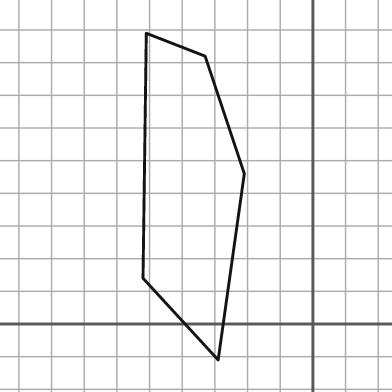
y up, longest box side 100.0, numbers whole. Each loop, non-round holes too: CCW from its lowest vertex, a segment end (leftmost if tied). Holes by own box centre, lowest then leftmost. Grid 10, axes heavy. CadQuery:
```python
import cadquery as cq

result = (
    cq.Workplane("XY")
    .moveTo(-29.0, -11.0)
    .lineTo(-21.0, 46.0)
    .lineTo(-33.0, 82.0)
    .lineTo(-51.0, 89.0)
    .lineTo(-52.0, 14.0)
    .close()
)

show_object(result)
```